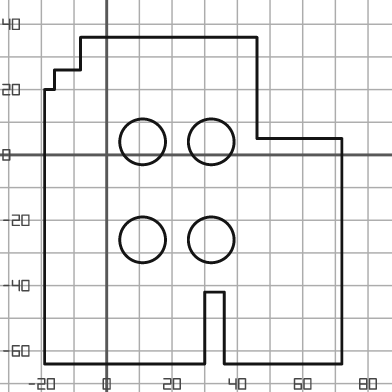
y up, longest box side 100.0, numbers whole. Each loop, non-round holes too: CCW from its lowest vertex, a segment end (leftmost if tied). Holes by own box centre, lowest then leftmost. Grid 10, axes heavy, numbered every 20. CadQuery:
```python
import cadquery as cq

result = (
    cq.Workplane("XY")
    .moveTo(-19.0, -64.0)
    .lineTo(30.0, -64.0)
    .lineTo(30.0, -42.0)
    .lineTo(36.0, -42.0)
    .lineTo(36.0, -64.0)
    .lineTo(72.0, -64.0)
    .lineTo(72.0, 5.0)
    .lineTo(46.0, 5.0)
    .lineTo(46.0, 36.0)
    .lineTo(-8.0, 36.0)
    .lineTo(-8.0, 26.0)
    .lineTo(-16.0, 26.0)
    .lineTo(-16.0, 20.0)
    .lineTo(-19.0, 20.0)
    .close()
    .moveTo(11.0, -26.0)
    .circle(7.0)
    .moveTo(32.0, -26.0)
    .circle(7.0)
    .moveTo(11.0, 4.0)
    .circle(7.0)
    .moveTo(32.0, 4.0)
    .circle(7.0)
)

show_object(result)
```